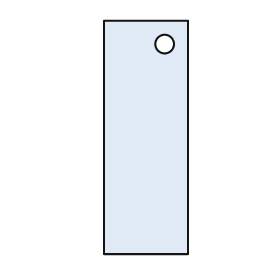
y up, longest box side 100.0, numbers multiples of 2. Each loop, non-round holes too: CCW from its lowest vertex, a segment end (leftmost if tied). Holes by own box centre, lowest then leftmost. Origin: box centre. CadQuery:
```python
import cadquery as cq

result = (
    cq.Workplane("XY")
    .moveTo(-18.0, -50.0)
    .lineTo(18.0, -50.0)
    .lineTo(18.0, 50.0)
    .lineTo(-18.0, 50.0)
    .close()
    .moveTo(8.0, 40.0)
    .circle(4.0)
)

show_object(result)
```